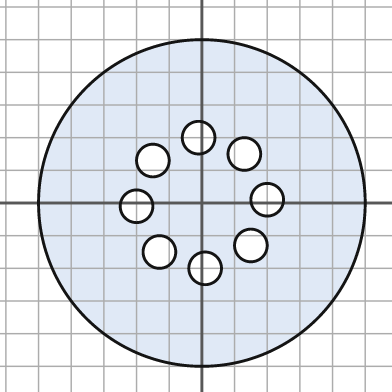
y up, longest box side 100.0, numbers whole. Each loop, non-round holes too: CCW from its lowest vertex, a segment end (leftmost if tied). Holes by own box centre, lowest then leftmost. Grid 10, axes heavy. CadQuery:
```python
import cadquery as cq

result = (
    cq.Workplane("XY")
    .moveTo(0.0, 0.0)
    .circle(50.0)
    .moveTo(1.0, -20.0)
    .circle(5.0)
    .moveTo(-13.0, -15.0)
    .circle(5.0)
    .moveTo(15.0, -13.0)
    .circle(5.0)
    .moveTo(-20.0, -1.0)
    .circle(5.0)
    .moveTo(20.0, 1.0)
    .circle(5.0)
    .moveTo(-15.0, 13.0)
    .circle(5.0)
    .moveTo(13.0, 15.0)
    .circle(5.0)
    .moveTo(-1.0, 20.0)
    .circle(5.0)
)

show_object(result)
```